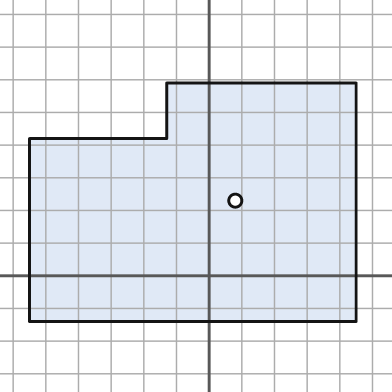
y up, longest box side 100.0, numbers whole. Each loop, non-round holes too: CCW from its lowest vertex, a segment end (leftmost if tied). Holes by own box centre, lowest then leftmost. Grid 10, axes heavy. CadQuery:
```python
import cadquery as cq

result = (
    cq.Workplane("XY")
    .moveTo(-55.0, -14.0)
    .lineTo(45.0, -14.0)
    .lineTo(45.0, 59.0)
    .lineTo(-13.0, 59.0)
    .lineTo(-13.0, 42.0)
    .lineTo(-55.0, 42.0)
    .close()
    .moveTo(8.0, 23.0)
    .circle(2.0)
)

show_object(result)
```